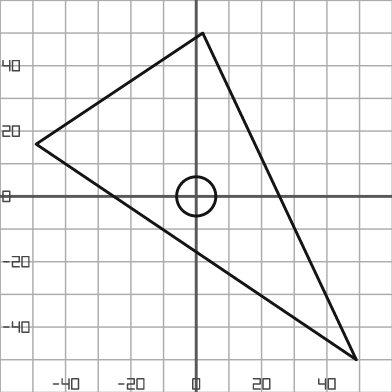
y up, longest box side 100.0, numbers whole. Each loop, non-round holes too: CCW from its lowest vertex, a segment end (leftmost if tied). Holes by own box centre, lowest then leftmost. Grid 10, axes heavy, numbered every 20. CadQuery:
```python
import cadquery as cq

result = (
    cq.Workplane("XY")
    .moveTo(49.0, -50.0)
    .lineTo(2.0, 50.0)
    .lineTo(-49.0, 16.0)
    .close()
    .moveTo(0.0, 0.0)
    .circle(6.0)
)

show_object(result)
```